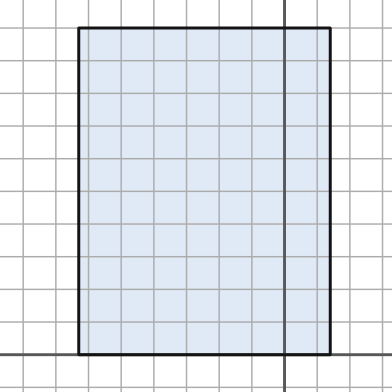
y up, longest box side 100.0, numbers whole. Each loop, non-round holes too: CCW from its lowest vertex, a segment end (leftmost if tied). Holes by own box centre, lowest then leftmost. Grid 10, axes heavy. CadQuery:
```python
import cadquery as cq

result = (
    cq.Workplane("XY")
    .moveTo(-63.0, 0.0)
    .lineTo(14.0, 0.0)
    .lineTo(14.0, 100.0)
    .lineTo(-63.0, 100.0)
    .close()
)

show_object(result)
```